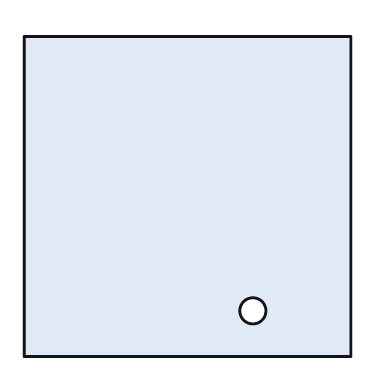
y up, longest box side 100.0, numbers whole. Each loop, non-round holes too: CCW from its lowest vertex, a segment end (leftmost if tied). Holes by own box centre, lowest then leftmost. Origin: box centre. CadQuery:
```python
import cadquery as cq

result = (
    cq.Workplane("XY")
    .moveTo(-50.0, -49.0)
    .lineTo(50.0, -49.0)
    .lineTo(50.0, 49.0)
    .lineTo(-50.0, 49.0)
    .close()
    .moveTo(20.0, -35.0)
    .circle(4.0)
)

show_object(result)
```